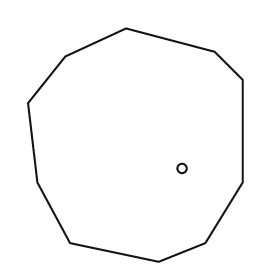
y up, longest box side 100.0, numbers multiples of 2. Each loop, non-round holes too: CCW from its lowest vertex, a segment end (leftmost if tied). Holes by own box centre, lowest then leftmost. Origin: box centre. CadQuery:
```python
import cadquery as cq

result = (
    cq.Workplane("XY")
    .moveTo(10.0, -50.0)
    .lineTo(30.0, -42.0)
    .lineTo(46.0, -16.0)
    .lineTo(46.0, 28.0)
    .lineTo(34.0, 40.0)
    .lineTo(-4.0, 50.0)
    .lineTo(-30.0, 38.0)
    .lineTo(-46.0, 18.0)
    .lineTo(-42.0, -16.0)
    .lineTo(-28.0, -42.0)
    .close()
    .moveTo(20.0, -10.0)
    .circle(2.0)
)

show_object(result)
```